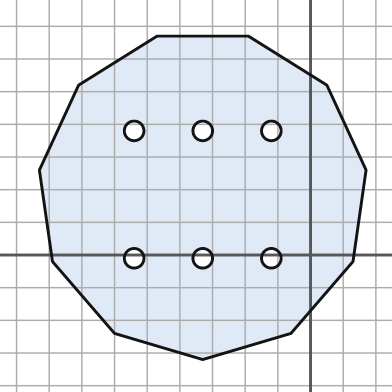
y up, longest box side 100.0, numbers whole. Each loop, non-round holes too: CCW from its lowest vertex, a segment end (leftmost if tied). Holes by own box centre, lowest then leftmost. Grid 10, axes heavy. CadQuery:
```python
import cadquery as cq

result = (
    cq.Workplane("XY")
    .moveTo(-33.0, -32.0)
    .lineTo(-6.0, -24.0)
    .lineTo(13.0, -2.0)
    .lineTo(17.0, 26.0)
    .lineTo(5.0, 52.0)
    .lineTo(-19.0, 67.0)
    .lineTo(-47.0, 67.0)
    .lineTo(-71.0, 52.0)
    .lineTo(-83.0, 26.0)
    .lineTo(-79.0, -2.0)
    .lineTo(-60.0, -24.0)
    .close()
    .moveTo(-54.0, -1.0)
    .circle(3.0)
    .moveTo(-33.0, -1.0)
    .circle(3.0)
    .moveTo(-12.0, -1.0)
    .circle(3.0)
    .moveTo(-54.0, 38.0)
    .circle(3.0)
    .moveTo(-33.0, 38.0)
    .circle(3.0)
    .moveTo(-12.0, 38.0)
    .circle(3.0)
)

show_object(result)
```